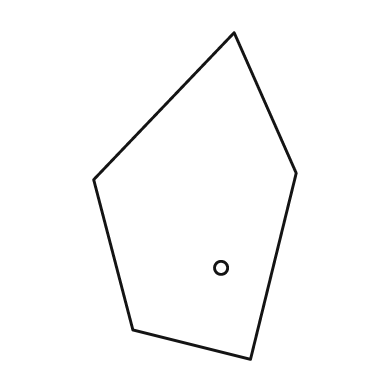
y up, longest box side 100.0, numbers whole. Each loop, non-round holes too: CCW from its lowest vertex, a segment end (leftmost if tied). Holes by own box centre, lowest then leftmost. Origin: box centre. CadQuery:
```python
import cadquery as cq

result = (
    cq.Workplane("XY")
    .moveTo(17.0, -50.0)
    .lineTo(31.0, 7.0)
    .lineTo(12.0, 50.0)
    .lineTo(-31.0, 5.0)
    .lineTo(-19.0, -41.0)
    .close()
    .moveTo(8.0, -22.0)
    .circle(2.0)
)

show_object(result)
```